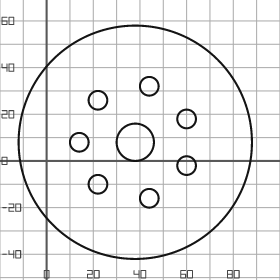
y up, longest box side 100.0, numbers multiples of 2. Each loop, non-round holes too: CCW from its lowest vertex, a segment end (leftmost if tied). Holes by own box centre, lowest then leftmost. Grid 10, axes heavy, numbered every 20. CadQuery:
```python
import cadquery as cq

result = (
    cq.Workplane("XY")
    .moveTo(38.0, 8.0)
    .circle(50.0)
    .moveTo(44.0, -16.0)
    .circle(4.0)
    .moveTo(22.0, -10.0)
    .circle(4.0)
    .moveTo(60.0, -2.0)
    .circle(4.0)
    .moveTo(14.0, 8.0)
    .circle(4.0)
    .moveTo(38.0, 8.0)
    .circle(8.0)
    .moveTo(60.0, 18.0)
    .circle(4.0)
    .moveTo(22.0, 26.0)
    .circle(4.0)
    .moveTo(44.0, 32.0)
    .circle(4.0)
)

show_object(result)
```